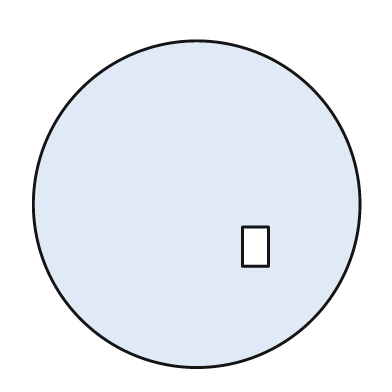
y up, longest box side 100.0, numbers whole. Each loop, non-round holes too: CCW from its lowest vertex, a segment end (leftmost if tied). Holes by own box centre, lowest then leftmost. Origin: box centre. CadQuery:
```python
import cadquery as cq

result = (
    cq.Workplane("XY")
    .moveTo(0.0, 0.0)
    .circle(50.0)
    .moveTo(14.0, -19.0)
    .lineTo(22.0, -19.0)
    .lineTo(22.0, -7.0)
    .lineTo(14.0, -7.0)
    .close()
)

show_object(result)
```